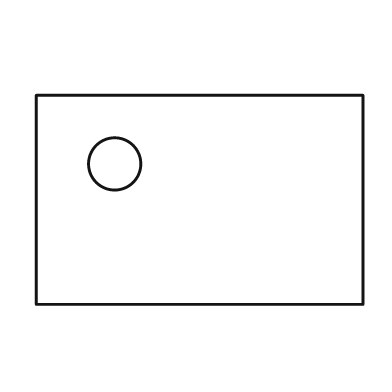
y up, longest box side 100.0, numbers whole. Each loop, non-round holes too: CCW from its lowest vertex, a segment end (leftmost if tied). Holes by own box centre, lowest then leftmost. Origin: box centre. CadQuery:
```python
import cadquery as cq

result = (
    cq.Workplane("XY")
    .moveTo(-50.0, -32.0)
    .lineTo(50.0, -32.0)
    .lineTo(50.0, 32.0)
    .lineTo(-50.0, 32.0)
    .close()
    .moveTo(-26.0, 11.0)
    .circle(8.0)
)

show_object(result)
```